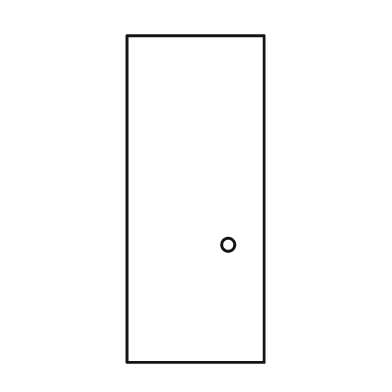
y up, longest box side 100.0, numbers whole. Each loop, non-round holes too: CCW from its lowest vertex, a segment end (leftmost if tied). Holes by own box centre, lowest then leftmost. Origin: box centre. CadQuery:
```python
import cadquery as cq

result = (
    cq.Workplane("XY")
    .moveTo(-21.0, -50.0)
    .lineTo(21.0, -50.0)
    .lineTo(21.0, 50.0)
    .lineTo(-21.0, 50.0)
    .close()
    .moveTo(10.0, -14.0)
    .circle(2.0)
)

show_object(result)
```